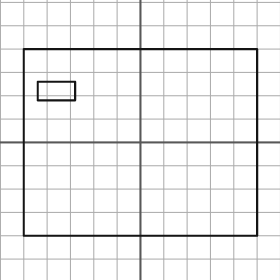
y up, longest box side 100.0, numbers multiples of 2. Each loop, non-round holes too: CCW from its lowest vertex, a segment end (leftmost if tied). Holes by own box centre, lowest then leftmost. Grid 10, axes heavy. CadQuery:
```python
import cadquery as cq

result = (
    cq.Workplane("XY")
    .moveTo(-50.0, -40.0)
    .lineTo(50.0, -40.0)
    .lineTo(50.0, 40.0)
    .lineTo(-50.0, 40.0)
    .close()
    .moveTo(-44.0, 18.0)
    .lineTo(-28.0, 18.0)
    .lineTo(-28.0, 26.0)
    .lineTo(-44.0, 26.0)
    .close()
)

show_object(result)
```